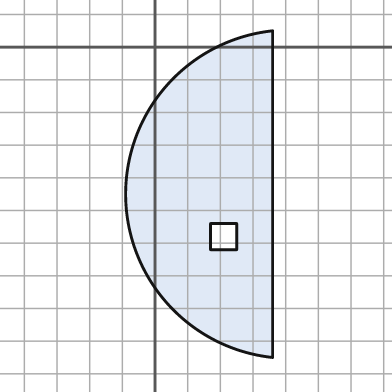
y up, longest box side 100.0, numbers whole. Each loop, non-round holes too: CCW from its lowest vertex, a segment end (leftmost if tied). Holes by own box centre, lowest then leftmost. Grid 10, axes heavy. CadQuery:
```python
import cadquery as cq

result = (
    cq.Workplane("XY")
    .moveTo(36.0, -95.0)
    .lineTo(36.0, 5.0)
    .threePointArc((-9.0, -45.0), (36.0, -95.0))
    .close()
    .moveTo(17.0, -62.0)
    .lineTo(25.0, -62.0)
    .lineTo(25.0, -54.0)
    .lineTo(17.0, -54.0)
    .close()
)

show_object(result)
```